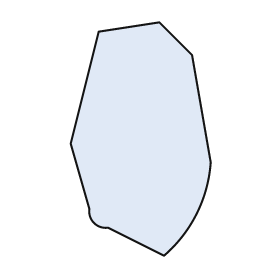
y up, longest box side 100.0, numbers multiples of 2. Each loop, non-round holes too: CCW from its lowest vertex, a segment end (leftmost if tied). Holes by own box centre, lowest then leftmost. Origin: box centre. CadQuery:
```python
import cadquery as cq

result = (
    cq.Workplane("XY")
    .moveTo(10.0, -50.0)
    .threePointArc((24.0, -32.0), (30.0, -10.0))
    .lineTo(22.0, 36.0)
    .lineTo(8.0, 50.0)
    .lineTo(-18.0, 46.0)
    .lineTo(-30.0, -2.0)
    .lineTo(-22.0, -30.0)
    .threePointArc((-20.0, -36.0), (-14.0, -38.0))
    .close()
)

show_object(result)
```